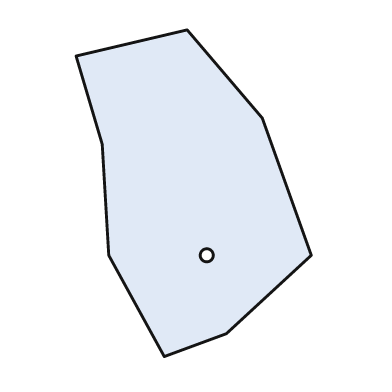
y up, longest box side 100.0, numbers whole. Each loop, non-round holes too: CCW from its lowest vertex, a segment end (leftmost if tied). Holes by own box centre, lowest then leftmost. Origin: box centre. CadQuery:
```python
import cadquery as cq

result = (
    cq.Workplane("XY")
    .moveTo(-9.0, -50.0)
    .lineTo(10.0, -43.0)
    .lineTo(36.0, -19.0)
    .lineTo(21.0, 23.0)
    .lineTo(-2.0, 50.0)
    .lineTo(-36.0, 42.0)
    .lineTo(-28.0, 15.0)
    .lineTo(-26.0, -19.0)
    .close()
    .moveTo(4.0, -19.0)
    .circle(2.0)
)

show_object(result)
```